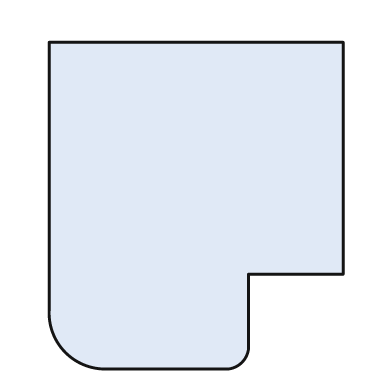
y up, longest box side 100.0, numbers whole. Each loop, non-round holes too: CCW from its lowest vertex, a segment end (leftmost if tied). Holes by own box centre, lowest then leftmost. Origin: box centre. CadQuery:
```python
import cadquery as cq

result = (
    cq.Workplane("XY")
    .moveTo(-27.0, -50.0)
    .lineTo(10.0, -50.0)
    .threePointArc((14.0, -48.0), (16.0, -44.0))
    .lineTo(16.0, -21.0)
    .lineTo(45.0, -21.0)
    .lineTo(45.0, 50.0)
    .lineTo(-45.0, 50.0)
    .lineTo(-45.0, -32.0)
    .threePointArc((-40.0, -45.0), (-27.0, -50.0))
    .close()
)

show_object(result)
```